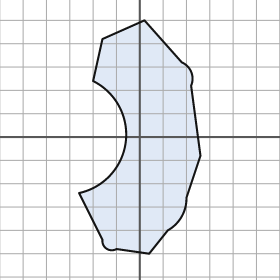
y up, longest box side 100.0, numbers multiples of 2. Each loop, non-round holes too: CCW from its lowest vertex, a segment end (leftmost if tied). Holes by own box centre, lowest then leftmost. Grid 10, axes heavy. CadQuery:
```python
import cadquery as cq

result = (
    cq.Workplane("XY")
    .moveTo(4.0, -50.0)
    .lineTo(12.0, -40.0)
    .threePointArc((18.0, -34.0), (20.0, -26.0))
    .lineTo(26.0, -8.0)
    .lineTo(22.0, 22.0)
    .threePointArc((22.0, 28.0), (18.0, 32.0))
    .lineTo(2.0, 50.0)
    .lineTo(-16.0, 42.0)
    .lineTo(-20.0, 24.0)
    .threePointArc((-6.0, -2.0), (-26.0, -24.0))
    .lineTo(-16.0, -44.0)
    .threePointArc((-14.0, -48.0), (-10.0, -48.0))
    .close()
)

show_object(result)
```